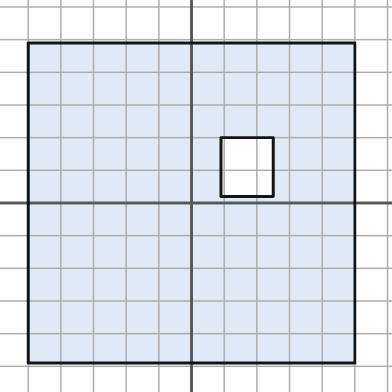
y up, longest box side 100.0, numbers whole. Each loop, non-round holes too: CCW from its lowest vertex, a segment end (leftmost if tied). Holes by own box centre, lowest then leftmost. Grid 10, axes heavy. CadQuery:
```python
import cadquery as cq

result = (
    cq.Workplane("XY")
    .moveTo(-50.0, -49.0)
    .lineTo(50.0, -49.0)
    .lineTo(50.0, 49.0)
    .lineTo(-50.0, 49.0)
    .close()
    .moveTo(9.0, 2.0)
    .lineTo(25.0, 2.0)
    .lineTo(25.0, 20.0)
    .lineTo(9.0, 20.0)
    .close()
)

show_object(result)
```